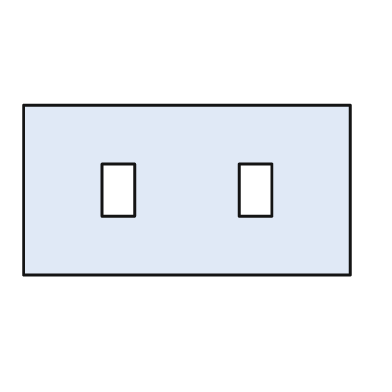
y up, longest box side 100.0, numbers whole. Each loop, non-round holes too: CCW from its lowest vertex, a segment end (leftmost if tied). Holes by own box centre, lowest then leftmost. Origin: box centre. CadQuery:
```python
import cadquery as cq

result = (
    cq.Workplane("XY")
    .moveTo(-50.0, -26.0)
    .lineTo(50.0, -26.0)
    .lineTo(50.0, 26.0)
    .lineTo(-50.0, 26.0)
    .close()
    .moveTo(-26.0, -8.0)
    .lineTo(-16.0, -8.0)
    .lineTo(-16.0, 8.0)
    .lineTo(-26.0, 8.0)
    .close()
    .moveTo(16.0, -8.0)
    .lineTo(26.0, -8.0)
    .lineTo(26.0, 8.0)
    .lineTo(16.0, 8.0)
    .close()
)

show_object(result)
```